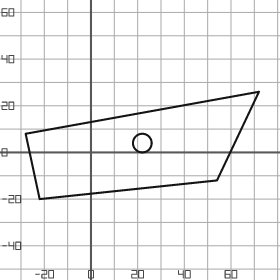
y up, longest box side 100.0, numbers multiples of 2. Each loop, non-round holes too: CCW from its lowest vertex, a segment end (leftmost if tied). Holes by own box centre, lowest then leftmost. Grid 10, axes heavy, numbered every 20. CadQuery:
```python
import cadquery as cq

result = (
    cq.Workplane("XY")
    .moveTo(-22.0, -20.0)
    .lineTo(54.0, -12.0)
    .lineTo(72.0, 26.0)
    .lineTo(-28.0, 8.0)
    .close()
    .moveTo(22.0, 4.0)
    .circle(4.0)
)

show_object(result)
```